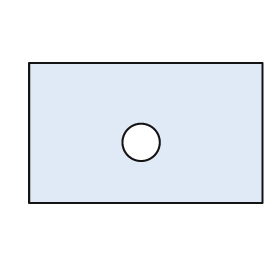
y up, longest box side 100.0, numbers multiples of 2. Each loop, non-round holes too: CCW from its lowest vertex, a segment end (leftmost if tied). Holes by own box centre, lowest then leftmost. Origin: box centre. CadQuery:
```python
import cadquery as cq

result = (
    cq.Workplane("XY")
    .moveTo(-50.0, -30.0)
    .lineTo(50.0, -30.0)
    .lineTo(50.0, 30.0)
    .lineTo(-50.0, 30.0)
    .close()
    .moveTo(-2.0, -4.0)
    .circle(8.0)
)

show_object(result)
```